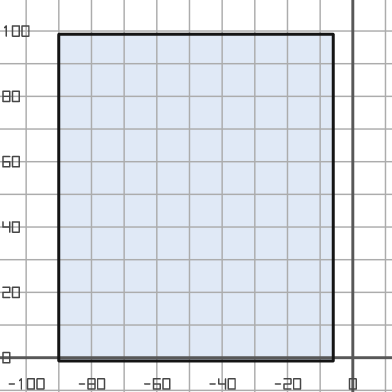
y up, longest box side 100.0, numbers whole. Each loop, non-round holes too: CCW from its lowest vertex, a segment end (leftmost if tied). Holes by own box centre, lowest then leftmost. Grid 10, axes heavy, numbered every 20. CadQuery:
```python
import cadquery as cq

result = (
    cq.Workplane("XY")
    .moveTo(-90.0, -1.0)
    .lineTo(-6.0, -1.0)
    .lineTo(-6.0, 99.0)
    .lineTo(-90.0, 99.0)
    .close()
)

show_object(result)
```